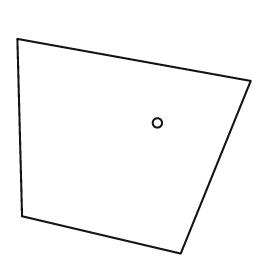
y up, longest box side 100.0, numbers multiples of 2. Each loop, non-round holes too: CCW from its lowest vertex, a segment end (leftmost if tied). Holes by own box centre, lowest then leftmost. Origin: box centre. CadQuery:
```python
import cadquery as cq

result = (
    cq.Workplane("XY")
    .moveTo(20.0, -46.0)
    .lineTo(50.0, 28.0)
    .lineTo(-50.0, 46.0)
    .lineTo(-48.0, -30.0)
    .close()
    .moveTo(10.0, 10.0)
    .circle(2.0)
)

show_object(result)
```